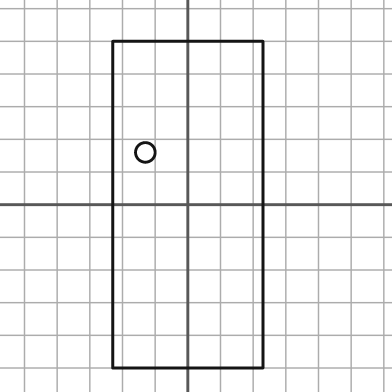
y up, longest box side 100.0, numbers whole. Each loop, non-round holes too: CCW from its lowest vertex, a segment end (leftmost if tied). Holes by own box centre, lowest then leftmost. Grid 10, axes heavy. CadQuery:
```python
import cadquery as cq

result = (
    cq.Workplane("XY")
    .moveTo(-23.0, -50.0)
    .lineTo(23.0, -50.0)
    .lineTo(23.0, 50.0)
    .lineTo(-23.0, 50.0)
    .close()
    .moveTo(-13.0, 16.0)
    .circle(3.0)
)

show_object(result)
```